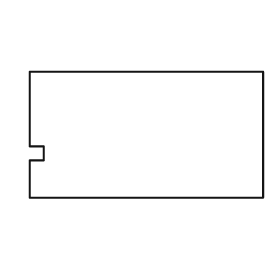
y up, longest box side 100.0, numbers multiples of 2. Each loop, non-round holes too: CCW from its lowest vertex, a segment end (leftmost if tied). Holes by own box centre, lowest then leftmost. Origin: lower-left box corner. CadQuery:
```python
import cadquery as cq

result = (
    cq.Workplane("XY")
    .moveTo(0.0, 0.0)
    .lineTo(100.0, 0.0)
    .lineTo(100.0, 54.0)
    .lineTo(0.0, 54.0)
    .lineTo(0.0, 22.0)
    .lineTo(6.0, 22.0)
    .lineTo(6.0, 16.0)
    .lineTo(0.0, 16.0)
    .close()
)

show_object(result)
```